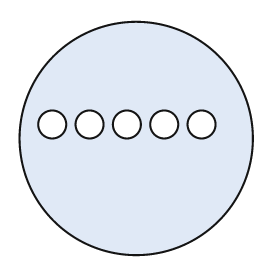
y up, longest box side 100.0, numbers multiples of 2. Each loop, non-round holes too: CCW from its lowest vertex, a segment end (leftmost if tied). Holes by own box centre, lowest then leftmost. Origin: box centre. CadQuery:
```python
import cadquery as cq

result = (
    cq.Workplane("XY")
    .moveTo(0.0, 0.0)
    .circle(50.0)
    .moveTo(-36.0, 6.0)
    .circle(6.0)
    .moveTo(-20.0, 6.0)
    .circle(6.0)
    .moveTo(-4.0, 6.0)
    .circle(6.0)
    .moveTo(12.0, 6.0)
    .circle(6.0)
    .moveTo(28.0, 6.0)
    .circle(6.0)
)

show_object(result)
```